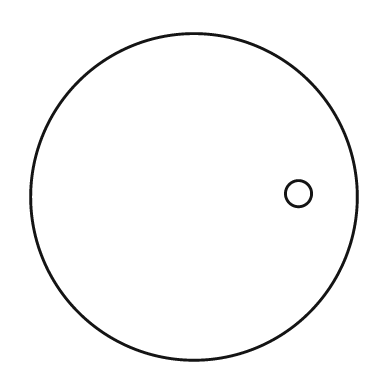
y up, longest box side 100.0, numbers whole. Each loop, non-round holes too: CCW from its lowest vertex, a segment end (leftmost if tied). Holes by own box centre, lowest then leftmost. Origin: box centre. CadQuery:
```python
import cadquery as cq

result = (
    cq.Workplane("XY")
    .moveTo(0.0, 0.0)
    .circle(50.0)
    .moveTo(32.0, 1.0)
    .circle(4.0)
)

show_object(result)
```